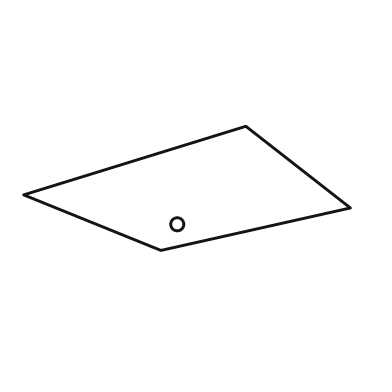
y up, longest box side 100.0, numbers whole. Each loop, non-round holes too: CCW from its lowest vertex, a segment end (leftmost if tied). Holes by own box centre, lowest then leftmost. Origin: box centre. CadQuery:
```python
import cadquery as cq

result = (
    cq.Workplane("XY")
    .moveTo(-8.0, -19.0)
    .lineTo(50.0, -6.0)
    .lineTo(18.0, 19.0)
    .lineTo(-50.0, -2.0)
    .close()
    .moveTo(-3.0, -11.0)
    .circle(2.0)
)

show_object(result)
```